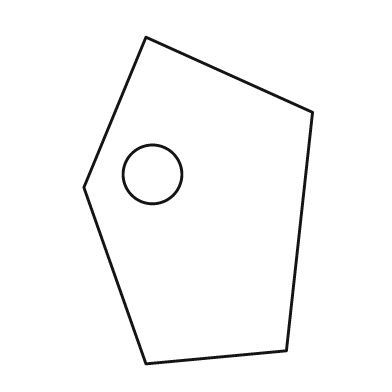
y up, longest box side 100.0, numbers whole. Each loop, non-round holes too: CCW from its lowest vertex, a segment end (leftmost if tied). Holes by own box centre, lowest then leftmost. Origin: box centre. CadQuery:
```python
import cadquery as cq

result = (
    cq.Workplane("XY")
    .moveTo(-16.0, -50.0)
    .lineTo(27.0, -46.0)
    .lineTo(35.0, 27.0)
    .lineTo(-16.0, 50.0)
    .lineTo(-35.0, 4.0)
    .close()
    .moveTo(-14.0, 8.0)
    .circle(9.0)
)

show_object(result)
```